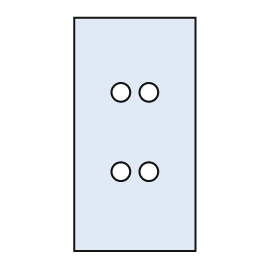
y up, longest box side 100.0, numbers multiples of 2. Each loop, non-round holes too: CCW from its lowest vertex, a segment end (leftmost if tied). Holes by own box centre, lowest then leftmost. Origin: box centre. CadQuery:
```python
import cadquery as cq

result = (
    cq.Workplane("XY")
    .moveTo(-26.0, -50.0)
    .lineTo(26.0, -50.0)
    .lineTo(26.0, 50.0)
    .lineTo(-26.0, 50.0)
    .close()
    .moveTo(-6.0, -16.0)
    .circle(4.0)
    .moveTo(6.0, -16.0)
    .circle(4.0)
    .moveTo(-6.0, 18.0)
    .circle(4.0)
    .moveTo(6.0, 18.0)
    .circle(4.0)
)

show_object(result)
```